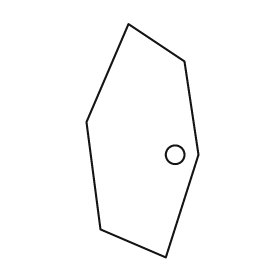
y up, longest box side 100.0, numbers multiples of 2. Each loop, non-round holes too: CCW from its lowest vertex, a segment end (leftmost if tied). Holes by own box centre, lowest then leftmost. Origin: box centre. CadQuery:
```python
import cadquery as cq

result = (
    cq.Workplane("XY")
    .moveTo(10.0, -50.0)
    .lineTo(24.0, -6.0)
    .lineTo(18.0, 34.0)
    .lineTo(-6.0, 50.0)
    .lineTo(-24.0, 8.0)
    .lineTo(-18.0, -38.0)
    .close()
    .moveTo(14.0, -6.0)
    .circle(4.0)
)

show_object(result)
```